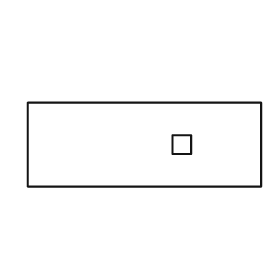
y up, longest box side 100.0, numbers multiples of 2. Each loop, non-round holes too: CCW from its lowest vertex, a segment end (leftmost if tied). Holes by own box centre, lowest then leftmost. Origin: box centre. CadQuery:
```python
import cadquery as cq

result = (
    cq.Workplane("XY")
    .moveTo(-50.0, -18.0)
    .lineTo(50.0, -18.0)
    .lineTo(50.0, 18.0)
    .lineTo(-50.0, 18.0)
    .close()
    .moveTo(12.0, -4.0)
    .lineTo(20.0, -4.0)
    .lineTo(20.0, 4.0)
    .lineTo(12.0, 4.0)
    .close()
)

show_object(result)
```